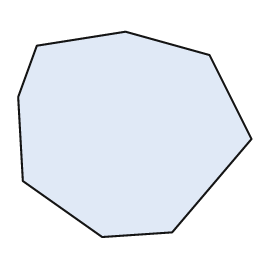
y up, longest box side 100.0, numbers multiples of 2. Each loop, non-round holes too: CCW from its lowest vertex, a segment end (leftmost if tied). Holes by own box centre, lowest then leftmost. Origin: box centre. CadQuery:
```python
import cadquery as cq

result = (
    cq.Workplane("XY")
    .moveTo(-14.0, -44.0)
    .lineTo(16.0, -42.0)
    .lineTo(50.0, -2.0)
    .lineTo(32.0, 34.0)
    .lineTo(-4.0, 44.0)
    .lineTo(-42.0, 38.0)
    .lineTo(-50.0, 16.0)
    .lineTo(-48.0, -20.0)
    .close()
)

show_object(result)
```